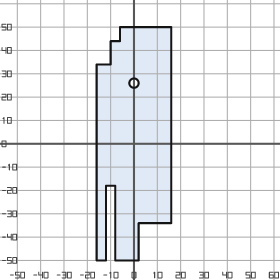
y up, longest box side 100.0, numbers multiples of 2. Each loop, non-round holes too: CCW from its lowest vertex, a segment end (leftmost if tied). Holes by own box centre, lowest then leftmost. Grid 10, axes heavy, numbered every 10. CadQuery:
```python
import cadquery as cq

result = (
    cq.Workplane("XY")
    .moveTo(-16.0, -50.0)
    .lineTo(-12.0, -50.0)
    .lineTo(-12.0, -18.0)
    .lineTo(-8.0, -18.0)
    .lineTo(-8.0, -50.0)
    .lineTo(2.0, -50.0)
    .lineTo(2.0, -34.0)
    .lineTo(16.0, -34.0)
    .lineTo(16.0, 50.0)
    .lineTo(-6.0, 50.0)
    .lineTo(-6.0, 44.0)
    .lineTo(-10.0, 44.0)
    .lineTo(-10.0, 34.0)
    .lineTo(-16.0, 34.0)
    .close()
    .moveTo(0.0, 26.0)
    .circle(2.0)
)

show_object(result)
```